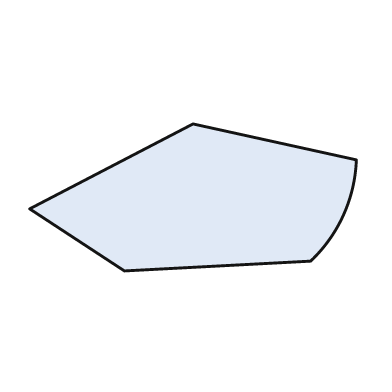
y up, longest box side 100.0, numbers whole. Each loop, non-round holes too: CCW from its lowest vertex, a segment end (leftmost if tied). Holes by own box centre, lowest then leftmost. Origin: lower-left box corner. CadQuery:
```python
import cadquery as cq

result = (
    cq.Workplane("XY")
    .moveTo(29.0, 0.0)
    .lineTo(86.0, 3.0)
    .threePointArc((96.0, 17.0), (100.0, 34.0))
    .lineTo(50.0, 45.0)
    .lineTo(0.0, 19.0)
    .close()
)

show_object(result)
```